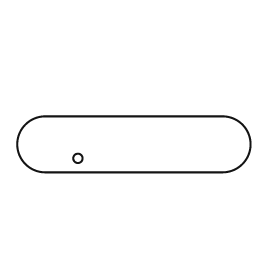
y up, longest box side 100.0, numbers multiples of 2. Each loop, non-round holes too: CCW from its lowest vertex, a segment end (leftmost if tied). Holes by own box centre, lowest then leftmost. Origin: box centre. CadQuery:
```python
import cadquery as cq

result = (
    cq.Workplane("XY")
    .moveTo(-38.0, -12.0)
    .lineTo(38.0, -12.0)
    .threePointArc((50.0, 0.0), (38.0, 12.0))
    .lineTo(-38.0, 12.0)
    .threePointArc((-50.0, 0.0), (-38.0, -12.0))
    .close()
    .moveTo(-24.0, -6.0)
    .circle(2.0)
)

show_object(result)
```